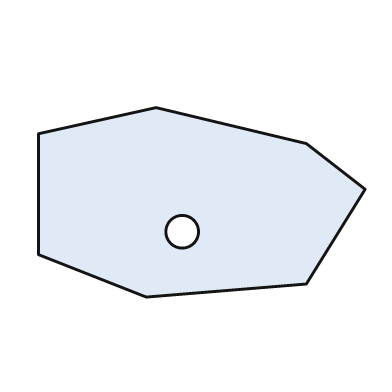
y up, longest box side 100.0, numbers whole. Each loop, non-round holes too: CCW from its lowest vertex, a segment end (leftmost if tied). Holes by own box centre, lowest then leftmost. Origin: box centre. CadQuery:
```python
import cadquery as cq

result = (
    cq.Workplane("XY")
    .moveTo(-17.0, -29.0)
    .lineTo(32.0, -25.0)
    .lineTo(50.0, 4.0)
    .lineTo(32.0, 18.0)
    .lineTo(-14.0, 29.0)
    .lineTo(-50.0, 21.0)
    .lineTo(-50.0, -16.0)
    .close()
    .moveTo(-6.0, -9.0)
    .circle(5.0)
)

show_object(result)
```